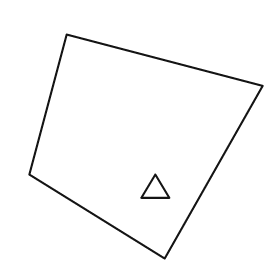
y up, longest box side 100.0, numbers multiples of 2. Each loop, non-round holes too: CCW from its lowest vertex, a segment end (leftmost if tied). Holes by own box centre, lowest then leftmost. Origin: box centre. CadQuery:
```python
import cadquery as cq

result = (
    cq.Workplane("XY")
    .moveTo(8.0, -48.0)
    .lineTo(50.0, 26.0)
    .lineTo(-34.0, 48.0)
    .lineTo(-50.0, -12.0)
    .close()
    .moveTo(-2.0, -22.0)
    .lineTo(10.0, -22.0)
    .lineTo(4.0, -12.0)
    .close()
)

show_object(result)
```